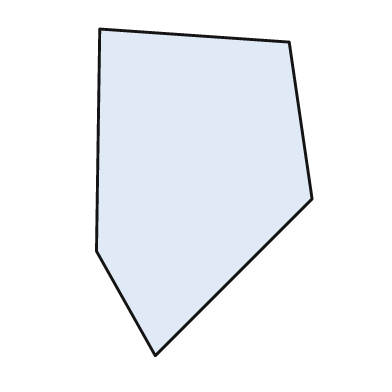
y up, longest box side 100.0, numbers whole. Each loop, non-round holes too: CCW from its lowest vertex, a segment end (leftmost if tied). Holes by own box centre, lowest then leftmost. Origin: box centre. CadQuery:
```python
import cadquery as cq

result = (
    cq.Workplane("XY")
    .moveTo(-15.0, -50.0)
    .lineTo(33.0, -2.0)
    .lineTo(26.0, 46.0)
    .lineTo(-32.0, 50.0)
    .lineTo(-33.0, -18.0)
    .close()
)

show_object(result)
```